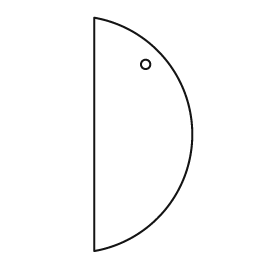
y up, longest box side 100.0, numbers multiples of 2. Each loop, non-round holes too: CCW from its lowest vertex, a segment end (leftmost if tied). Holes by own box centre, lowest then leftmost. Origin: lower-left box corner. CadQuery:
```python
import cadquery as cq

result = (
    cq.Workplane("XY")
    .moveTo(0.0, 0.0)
    .threePointArc((42.0, 50.0), (0.0, 100.0))
    .close()
    .moveTo(22.0, 80.0)
    .circle(2.0)
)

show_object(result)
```